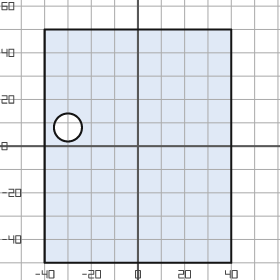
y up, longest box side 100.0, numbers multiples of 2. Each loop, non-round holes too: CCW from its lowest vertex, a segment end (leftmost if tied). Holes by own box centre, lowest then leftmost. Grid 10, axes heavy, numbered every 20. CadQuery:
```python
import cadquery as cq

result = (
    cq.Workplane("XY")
    .moveTo(-40.0, -50.0)
    .lineTo(40.0, -50.0)
    .lineTo(40.0, 50.0)
    .lineTo(-40.0, 50.0)
    .close()
    .moveTo(-30.0, 8.0)
    .circle(6.0)
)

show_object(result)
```